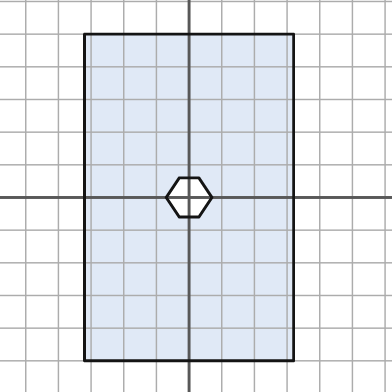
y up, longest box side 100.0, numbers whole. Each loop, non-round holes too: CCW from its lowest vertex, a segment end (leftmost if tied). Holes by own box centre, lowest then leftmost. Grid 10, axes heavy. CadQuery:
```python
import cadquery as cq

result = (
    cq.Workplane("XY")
    .moveTo(-32.0, -50.0)
    .lineTo(32.0, -50.0)
    .lineTo(32.0, 50.0)
    .lineTo(-32.0, 50.0)
    .close()
    .moveTo(-3.0, -6.0)
    .lineTo(3.0, -6.0)
    .lineTo(7.0, 0.0)
    .lineTo(3.0, 6.0)
    .lineTo(-3.0, 6.0)
    .lineTo(-7.0, 0.0)
    .close()
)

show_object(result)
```